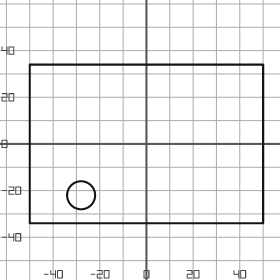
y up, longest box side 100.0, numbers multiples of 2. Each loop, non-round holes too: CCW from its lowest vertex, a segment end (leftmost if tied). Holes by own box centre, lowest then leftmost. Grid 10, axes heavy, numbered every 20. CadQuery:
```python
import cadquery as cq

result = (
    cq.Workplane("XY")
    .moveTo(-50.0, -34.0)
    .lineTo(50.0, -34.0)
    .lineTo(50.0, 34.0)
    .lineTo(-50.0, 34.0)
    .close()
    .moveTo(-28.0, -22.0)
    .circle(6.0)
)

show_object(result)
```